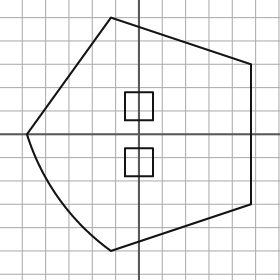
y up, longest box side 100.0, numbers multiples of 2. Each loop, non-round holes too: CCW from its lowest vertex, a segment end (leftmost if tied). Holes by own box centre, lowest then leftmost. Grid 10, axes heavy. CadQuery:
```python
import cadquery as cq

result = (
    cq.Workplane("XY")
    .moveTo(-12.0, -50.0)
    .lineTo(48.0, -30.0)
    .lineTo(48.0, 30.0)
    .lineTo(-12.0, 50.0)
    .lineTo(-48.0, 0.0)
    .threePointArc((-34.0, -28.0), (-12.0, -50.0))
    .close()
    .moveTo(-6.0, -18.0)
    .lineTo(6.0, -18.0)
    .lineTo(6.0, -6.0)
    .lineTo(-6.0, -6.0)
    .close()
    .moveTo(-6.0, 6.0)
    .lineTo(6.0, 6.0)
    .lineTo(6.0, 18.0)
    .lineTo(-6.0, 18.0)
    .close()
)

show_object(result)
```